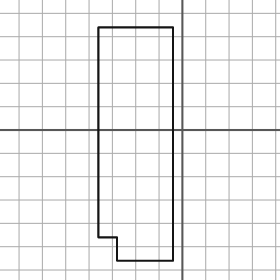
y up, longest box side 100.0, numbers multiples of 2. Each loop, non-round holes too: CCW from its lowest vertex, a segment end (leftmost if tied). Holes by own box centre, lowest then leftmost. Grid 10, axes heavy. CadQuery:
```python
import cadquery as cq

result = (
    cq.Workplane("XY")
    .moveTo(-28.0, -56.0)
    .lineTo(-4.0, -56.0)
    .lineTo(-4.0, 44.0)
    .lineTo(-36.0, 44.0)
    .lineTo(-36.0, -46.0)
    .lineTo(-28.0, -46.0)
    .close()
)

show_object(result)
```